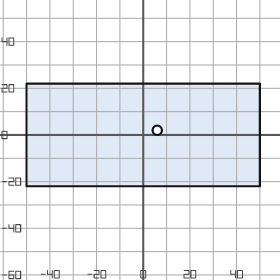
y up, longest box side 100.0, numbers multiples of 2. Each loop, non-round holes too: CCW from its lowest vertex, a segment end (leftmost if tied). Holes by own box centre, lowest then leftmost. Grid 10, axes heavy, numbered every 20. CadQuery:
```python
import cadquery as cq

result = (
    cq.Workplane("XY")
    .moveTo(-50.0, -22.0)
    .lineTo(50.0, -22.0)
    .lineTo(50.0, 22.0)
    .lineTo(-50.0, 22.0)
    .close()
    .moveTo(6.0, 2.0)
    .circle(2.0)
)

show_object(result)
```